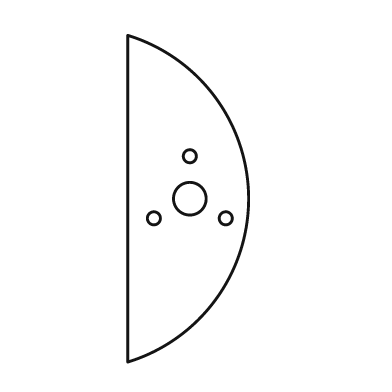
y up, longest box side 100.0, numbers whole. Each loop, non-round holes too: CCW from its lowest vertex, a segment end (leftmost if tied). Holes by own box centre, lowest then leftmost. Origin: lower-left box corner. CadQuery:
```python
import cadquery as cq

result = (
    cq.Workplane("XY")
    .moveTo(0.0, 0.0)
    .threePointArc((37.0, 50.0), (0.0, 100.0))
    .close()
    .moveTo(8.0, 44.0)
    .circle(2.0)
    .moveTo(30.0, 44.0)
    .circle(2.0)
    .moveTo(19.0, 50.0)
    .circle(5.0)
    .moveTo(19.0, 63.0)
    .circle(2.0)
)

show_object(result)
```